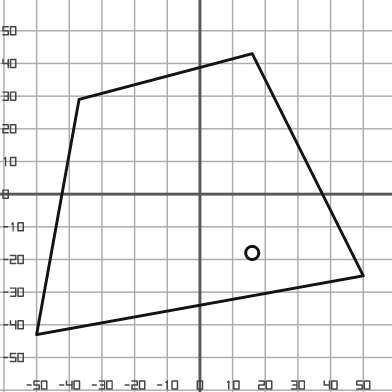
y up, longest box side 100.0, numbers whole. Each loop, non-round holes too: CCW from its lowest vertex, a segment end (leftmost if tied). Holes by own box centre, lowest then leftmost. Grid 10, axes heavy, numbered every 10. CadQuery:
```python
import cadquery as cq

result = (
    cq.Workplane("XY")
    .moveTo(-50.0, -43.0)
    .lineTo(50.0, -25.0)
    .lineTo(16.0, 43.0)
    .lineTo(-37.0, 29.0)
    .close()
    .moveTo(16.0, -18.0)
    .circle(2.0)
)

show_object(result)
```